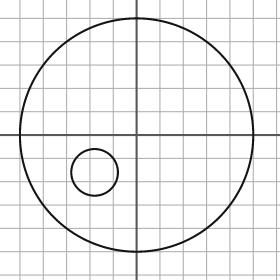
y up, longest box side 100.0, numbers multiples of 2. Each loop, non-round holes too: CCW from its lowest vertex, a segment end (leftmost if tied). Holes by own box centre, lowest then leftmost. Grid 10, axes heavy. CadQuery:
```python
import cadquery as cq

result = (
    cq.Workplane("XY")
    .moveTo(0.0, 0.0)
    .circle(50.0)
    .moveTo(-18.0, -16.0)
    .circle(10.0)
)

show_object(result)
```